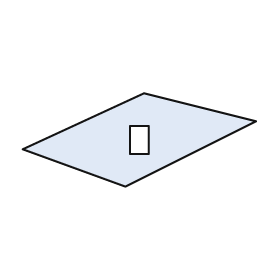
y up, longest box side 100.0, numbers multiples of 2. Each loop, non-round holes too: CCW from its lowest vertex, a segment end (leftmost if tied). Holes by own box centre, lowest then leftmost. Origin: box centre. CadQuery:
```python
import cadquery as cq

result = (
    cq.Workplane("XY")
    .moveTo(-6.0, -20.0)
    .lineTo(50.0, 8.0)
    .lineTo(2.0, 20.0)
    .lineTo(-50.0, -4.0)
    .close()
    .moveTo(-4.0, -6.0)
    .lineTo(4.0, -6.0)
    .lineTo(4.0, 6.0)
    .lineTo(-4.0, 6.0)
    .close()
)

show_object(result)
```